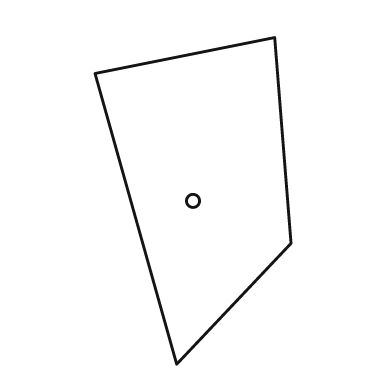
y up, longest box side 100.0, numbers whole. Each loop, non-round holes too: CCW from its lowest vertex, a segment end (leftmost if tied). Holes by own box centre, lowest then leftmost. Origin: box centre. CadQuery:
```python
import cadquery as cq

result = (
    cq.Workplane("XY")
    .moveTo(-5.0, -50.0)
    .lineTo(30.0, -13.0)
    .lineTo(25.0, 50.0)
    .lineTo(-30.0, 39.0)
    .close()
    .moveTo(0.0, 0.0)
    .circle(2.0)
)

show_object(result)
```